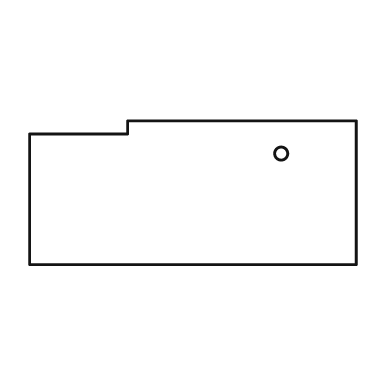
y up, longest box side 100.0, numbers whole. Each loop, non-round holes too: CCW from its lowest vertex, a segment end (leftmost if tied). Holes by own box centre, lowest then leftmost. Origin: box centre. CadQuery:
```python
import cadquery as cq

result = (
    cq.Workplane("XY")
    .moveTo(-50.0, -22.0)
    .lineTo(50.0, -22.0)
    .lineTo(50.0, 22.0)
    .lineTo(-20.0, 22.0)
    .lineTo(-20.0, 18.0)
    .lineTo(-50.0, 18.0)
    .close()
    .moveTo(27.0, 12.0)
    .circle(2.0)
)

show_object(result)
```